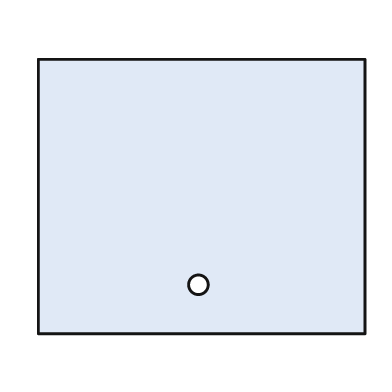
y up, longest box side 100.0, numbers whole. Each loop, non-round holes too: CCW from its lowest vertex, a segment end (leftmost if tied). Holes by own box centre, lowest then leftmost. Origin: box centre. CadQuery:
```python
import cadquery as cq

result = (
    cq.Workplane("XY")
    .moveTo(-50.0, -42.0)
    .lineTo(50.0, -42.0)
    .lineTo(50.0, 42.0)
    .lineTo(-50.0, 42.0)
    .close()
    .moveTo(-1.0, -27.0)
    .circle(3.0)
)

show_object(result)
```